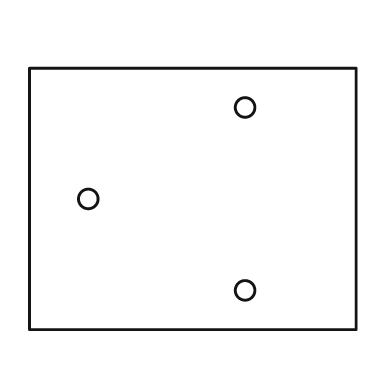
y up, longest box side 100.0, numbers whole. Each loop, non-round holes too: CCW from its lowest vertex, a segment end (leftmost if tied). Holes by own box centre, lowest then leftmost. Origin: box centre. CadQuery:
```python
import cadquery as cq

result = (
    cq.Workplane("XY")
    .moveTo(-50.0, -40.0)
    .lineTo(50.0, -40.0)
    .lineTo(50.0, 40.0)
    .lineTo(-50.0, 40.0)
    .close()
    .moveTo(16.0, -28.0)
    .circle(3.0)
    .moveTo(-32.0, 0.0)
    .circle(3.0)
    .moveTo(16.0, 28.0)
    .circle(3.0)
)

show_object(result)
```